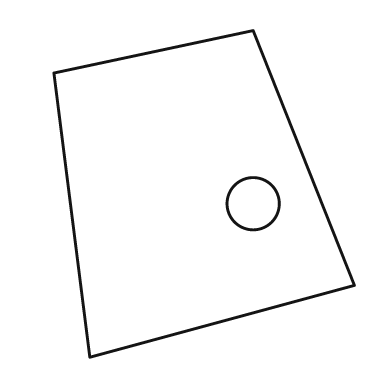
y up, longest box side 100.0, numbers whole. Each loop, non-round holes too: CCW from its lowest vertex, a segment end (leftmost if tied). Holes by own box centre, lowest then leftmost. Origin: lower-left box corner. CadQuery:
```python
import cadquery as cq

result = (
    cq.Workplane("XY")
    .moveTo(11.0, 0.0)
    .lineTo(92.0, 22.0)
    .lineTo(61.0, 100.0)
    .lineTo(0.0, 87.0)
    .close()
    .moveTo(61.0, 47.0)
    .circle(8.0)
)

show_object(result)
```